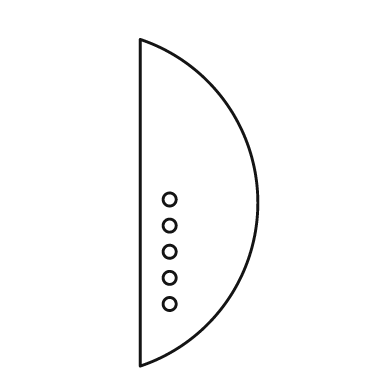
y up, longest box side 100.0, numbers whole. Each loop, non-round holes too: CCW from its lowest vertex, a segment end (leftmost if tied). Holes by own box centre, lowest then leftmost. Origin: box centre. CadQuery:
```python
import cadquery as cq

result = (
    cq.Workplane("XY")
    .moveTo(-18.0, -50.0)
    .threePointArc((18.0, 0.0), (-18.0, 50.0))
    .close()
    .moveTo(-9.0, -31.0)
    .circle(2.0)
    .moveTo(-9.0, -23.0)
    .circle(2.0)
    .moveTo(-9.0, -15.0)
    .circle(2.0)
    .moveTo(-9.0, -7.0)
    .circle(2.0)
    .moveTo(-9.0, 1.0)
    .circle(2.0)
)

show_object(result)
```